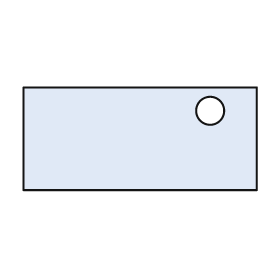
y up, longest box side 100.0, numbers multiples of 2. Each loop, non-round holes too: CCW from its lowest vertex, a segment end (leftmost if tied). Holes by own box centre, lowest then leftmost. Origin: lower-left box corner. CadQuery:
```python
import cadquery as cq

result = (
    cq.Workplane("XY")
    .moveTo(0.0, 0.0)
    .lineTo(100.0, 0.0)
    .lineTo(100.0, 44.0)
    .lineTo(0.0, 44.0)
    .close()
    .moveTo(80.0, 34.0)
    .circle(6.0)
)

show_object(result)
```